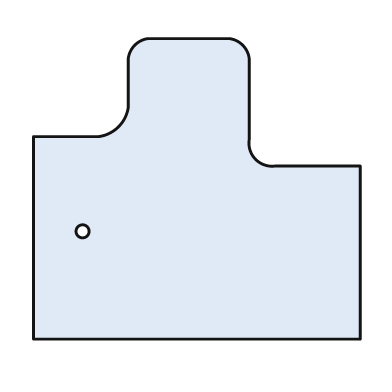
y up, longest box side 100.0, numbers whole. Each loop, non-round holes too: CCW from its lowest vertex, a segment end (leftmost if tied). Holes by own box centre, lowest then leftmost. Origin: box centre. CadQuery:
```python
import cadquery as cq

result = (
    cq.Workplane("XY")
    .moveTo(-50.0, -46.0)
    .lineTo(50.0, -46.0)
    .lineTo(50.0, 7.0)
    .lineTo(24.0, 7.0)
    .threePointArc((18.0, 9.0), (16.0, 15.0))
    .lineTo(16.0, 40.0)
    .threePointArc((14.0, 44.0), (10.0, 46.0))
    .lineTo(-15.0, 46.0)
    .threePointArc((-19.0, 44.0), (-21.0, 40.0))
    .lineTo(-21.0, 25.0)
    .threePointArc((-24.0, 19.0), (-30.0, 16.0))
    .lineTo(-50.0, 16.0)
    .close()
    .moveTo(-35.0, -13.0)
    .circle(2.0)
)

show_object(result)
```